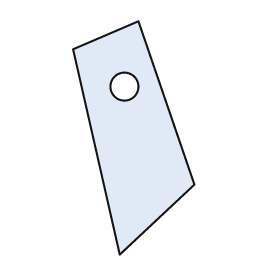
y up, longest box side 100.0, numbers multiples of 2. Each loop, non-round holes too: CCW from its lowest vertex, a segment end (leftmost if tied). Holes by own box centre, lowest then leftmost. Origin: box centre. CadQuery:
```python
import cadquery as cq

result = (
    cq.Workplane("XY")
    .moveTo(-6.0, -50.0)
    .lineTo(26.0, -20.0)
    .lineTo(2.0, 50.0)
    .lineTo(-26.0, 38.0)
    .close()
    .moveTo(-4.0, 22.0)
    .circle(6.0)
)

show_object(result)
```